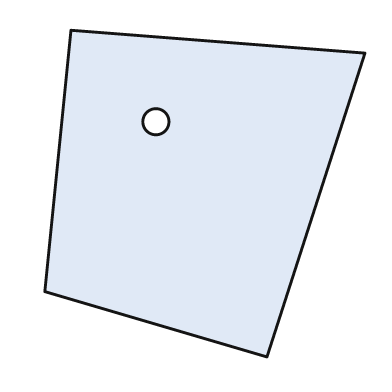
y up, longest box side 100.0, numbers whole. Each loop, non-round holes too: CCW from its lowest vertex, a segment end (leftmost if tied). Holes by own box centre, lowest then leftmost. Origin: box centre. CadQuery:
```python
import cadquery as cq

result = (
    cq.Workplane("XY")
    .moveTo(19.0, -50.0)
    .lineTo(49.0, 43.0)
    .lineTo(-41.0, 50.0)
    .lineTo(-49.0, -30.0)
    .close()
    .moveTo(-15.0, 22.0)
    .circle(4.0)
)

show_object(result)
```